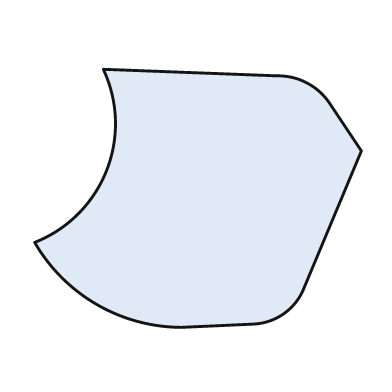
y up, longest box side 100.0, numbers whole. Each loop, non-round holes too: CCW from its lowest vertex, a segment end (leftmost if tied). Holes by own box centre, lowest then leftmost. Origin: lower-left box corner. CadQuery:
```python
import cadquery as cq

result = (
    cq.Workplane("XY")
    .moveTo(45.0, 0.0)
    .lineTo(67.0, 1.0)
    .threePointArc((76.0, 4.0), (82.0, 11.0))
    .lineTo(100.0, 54.0)
    .lineTo(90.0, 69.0)
    .threePointArc((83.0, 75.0), (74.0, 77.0))
    .lineTo(21.0, 79.0)
    .threePointArc((22.0, 48.0), (0.0, 26.0))
    .threePointArc((19.0, 7.0), (45.0, 0.0))
    .close()
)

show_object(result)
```